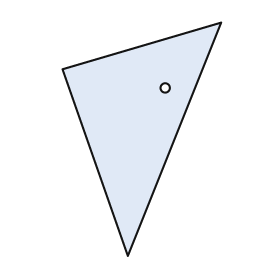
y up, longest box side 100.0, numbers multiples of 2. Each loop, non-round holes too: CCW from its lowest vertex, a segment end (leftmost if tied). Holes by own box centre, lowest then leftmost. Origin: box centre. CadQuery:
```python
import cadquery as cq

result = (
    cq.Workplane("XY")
    .moveTo(-6.0, -50.0)
    .lineTo(34.0, 50.0)
    .lineTo(-34.0, 30.0)
    .close()
    .moveTo(10.0, 22.0)
    .circle(2.0)
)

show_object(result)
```